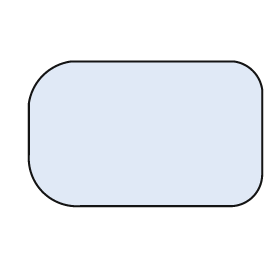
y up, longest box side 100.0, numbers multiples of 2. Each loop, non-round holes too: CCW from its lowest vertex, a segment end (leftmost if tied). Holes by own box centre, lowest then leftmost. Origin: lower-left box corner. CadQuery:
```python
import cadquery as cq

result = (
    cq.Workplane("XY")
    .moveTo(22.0, 0.0)
    .lineTo(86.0, 0.0)
    .threePointArc((96.0, 4.0), (100.0, 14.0))
    .lineTo(100.0, 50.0)
    .threePointArc((96.0, 58.0), (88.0, 62.0))
    .lineTo(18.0, 62.0)
    .threePointArc((6.0, 56.0), (0.0, 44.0))
    .lineTo(0.0, 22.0)
    .threePointArc((6.0, 6.0), (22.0, 0.0))
    .close()
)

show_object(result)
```